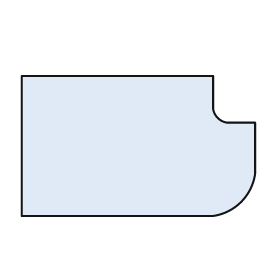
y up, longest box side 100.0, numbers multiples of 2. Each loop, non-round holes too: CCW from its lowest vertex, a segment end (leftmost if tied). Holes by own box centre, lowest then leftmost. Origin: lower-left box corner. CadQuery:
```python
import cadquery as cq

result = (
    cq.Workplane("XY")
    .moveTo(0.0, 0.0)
    .lineTo(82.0, 0.0)
    .threePointArc((94.0, 6.0), (100.0, 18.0))
    .lineTo(100.0, 40.0)
    .lineTo(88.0, 40.0)
    .threePointArc((84.0, 42.0), (82.0, 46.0))
    .lineTo(82.0, 60.0)
    .lineTo(0.0, 60.0)
    .close()
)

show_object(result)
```